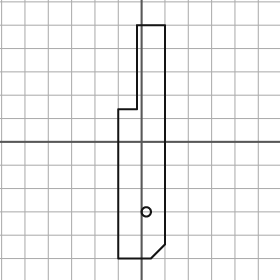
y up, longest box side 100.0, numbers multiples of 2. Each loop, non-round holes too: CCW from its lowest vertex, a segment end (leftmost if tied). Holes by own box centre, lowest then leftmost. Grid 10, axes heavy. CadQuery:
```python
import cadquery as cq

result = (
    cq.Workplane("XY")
    .moveTo(-10.0, -50.0)
    .lineTo(4.0, -50.0)
    .lineTo(10.0, -44.0)
    .lineTo(10.0, 50.0)
    .lineTo(-2.0, 50.0)
    .lineTo(-2.0, 14.0)
    .lineTo(-10.0, 14.0)
    .close()
    .moveTo(2.0, -30.0)
    .circle(2.0)
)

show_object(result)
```